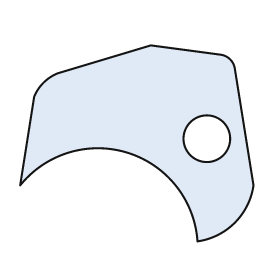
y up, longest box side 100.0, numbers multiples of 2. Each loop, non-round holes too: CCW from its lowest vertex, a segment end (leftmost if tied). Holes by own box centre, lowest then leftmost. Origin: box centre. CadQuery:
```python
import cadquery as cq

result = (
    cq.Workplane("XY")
    .moveTo(26.0, -42.0)
    .threePointArc((42.0, -34.0), (50.0, -18.0))
    .lineTo(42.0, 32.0)
    .threePointArc((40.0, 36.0), (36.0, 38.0))
    .lineTo(6.0, 42.0)
    .lineTo(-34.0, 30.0)
    .threePointArc((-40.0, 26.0), (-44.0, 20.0))
    .lineTo(-50.0, -18.0)
    .threePointArc((-4.0, -4.0), (26.0, -42.0))
    .close()
    .moveTo(30.0, 2.0)
    .circle(10.0)
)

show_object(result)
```